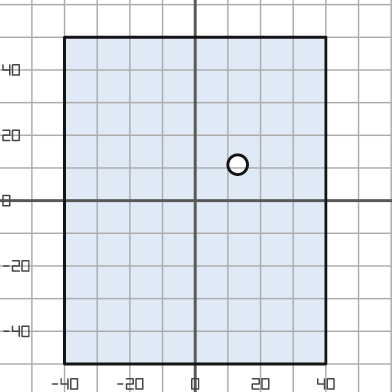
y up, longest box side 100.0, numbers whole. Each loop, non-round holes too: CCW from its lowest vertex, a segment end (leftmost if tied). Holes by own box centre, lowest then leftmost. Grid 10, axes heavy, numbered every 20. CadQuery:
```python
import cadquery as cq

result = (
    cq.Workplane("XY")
    .moveTo(-40.0, -50.0)
    .lineTo(40.0, -50.0)
    .lineTo(40.0, 50.0)
    .lineTo(-40.0, 50.0)
    .close()
    .moveTo(13.0, 11.0)
    .circle(3.0)
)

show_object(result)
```